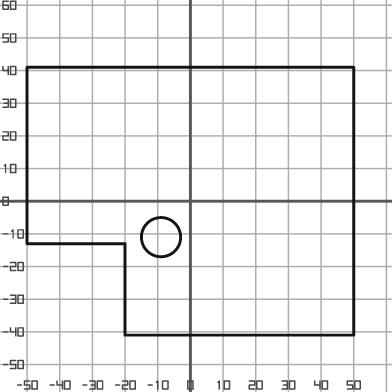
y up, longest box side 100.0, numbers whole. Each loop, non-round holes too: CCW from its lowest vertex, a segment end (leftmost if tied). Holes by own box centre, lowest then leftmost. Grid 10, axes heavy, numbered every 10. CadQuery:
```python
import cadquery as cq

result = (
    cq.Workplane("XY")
    .moveTo(-20.0, -41.0)
    .lineTo(50.0, -41.0)
    .lineTo(50.0, 41.0)
    .lineTo(-50.0, 41.0)
    .lineTo(-50.0, -13.0)
    .lineTo(-20.0, -13.0)
    .close()
    .moveTo(-9.0, -11.0)
    .circle(6.0)
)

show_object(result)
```